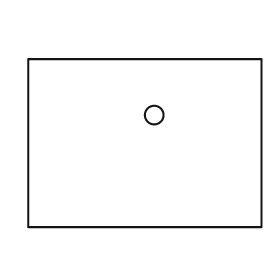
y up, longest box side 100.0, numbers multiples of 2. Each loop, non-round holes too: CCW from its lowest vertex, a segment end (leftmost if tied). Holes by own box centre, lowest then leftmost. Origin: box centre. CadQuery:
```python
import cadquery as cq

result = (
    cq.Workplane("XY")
    .moveTo(-50.0, -36.0)
    .lineTo(50.0, -36.0)
    .lineTo(50.0, 36.0)
    .lineTo(-50.0, 36.0)
    .close()
    .moveTo(4.0, 12.0)
    .circle(4.0)
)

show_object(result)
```